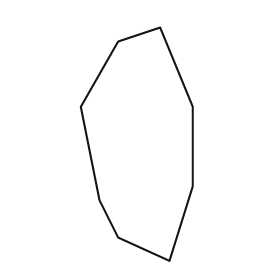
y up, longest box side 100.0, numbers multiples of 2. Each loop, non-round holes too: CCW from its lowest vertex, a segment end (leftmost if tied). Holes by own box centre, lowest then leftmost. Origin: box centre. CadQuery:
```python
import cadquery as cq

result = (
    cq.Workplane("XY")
    .moveTo(14.0, -50.0)
    .lineTo(24.0, -18.0)
    .lineTo(24.0, 16.0)
    .lineTo(10.0, 50.0)
    .lineTo(-8.0, 44.0)
    .lineTo(-24.0, 16.0)
    .lineTo(-16.0, -24.0)
    .lineTo(-8.0, -40.0)
    .close()
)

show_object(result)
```